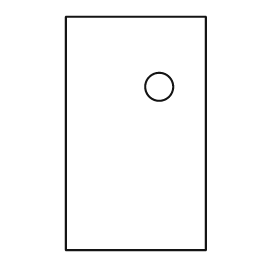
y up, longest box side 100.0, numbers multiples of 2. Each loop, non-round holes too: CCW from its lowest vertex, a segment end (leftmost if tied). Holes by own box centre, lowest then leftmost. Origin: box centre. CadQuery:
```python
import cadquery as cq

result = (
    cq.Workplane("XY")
    .moveTo(-30.0, -50.0)
    .lineTo(30.0, -50.0)
    .lineTo(30.0, 50.0)
    .lineTo(-30.0, 50.0)
    .close()
    .moveTo(10.0, 20.0)
    .circle(6.0)
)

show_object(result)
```